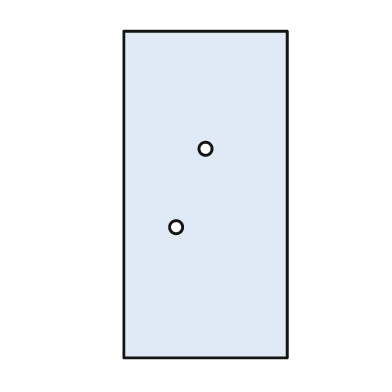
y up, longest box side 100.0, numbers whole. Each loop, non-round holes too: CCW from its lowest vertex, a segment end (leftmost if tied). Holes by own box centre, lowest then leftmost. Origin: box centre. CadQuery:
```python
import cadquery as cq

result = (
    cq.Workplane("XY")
    .moveTo(-25.0, -50.0)
    .lineTo(25.0, -50.0)
    .lineTo(25.0, 50.0)
    .lineTo(-25.0, 50.0)
    .close()
    .moveTo(-9.0, -10.0)
    .circle(2.0)
    .moveTo(0.0, 14.0)
    .circle(2.0)
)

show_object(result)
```